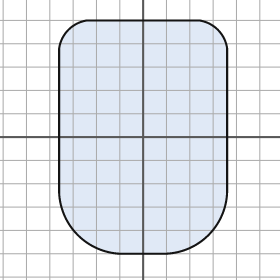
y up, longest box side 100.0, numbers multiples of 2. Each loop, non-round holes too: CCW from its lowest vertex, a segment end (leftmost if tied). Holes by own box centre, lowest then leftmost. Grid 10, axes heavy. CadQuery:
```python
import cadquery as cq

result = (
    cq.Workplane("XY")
    .moveTo(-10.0, -50.0)
    .lineTo(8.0, -50.0)
    .threePointArc((28.0, -42.0), (36.0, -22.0))
    .lineTo(36.0, 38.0)
    .threePointArc((32.0, 46.0), (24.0, 50.0))
    .lineTo(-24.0, 50.0)
    .threePointArc((-32.0, 46.0), (-36.0, 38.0))
    .lineTo(-36.0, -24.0)
    .threePointArc((-28.0, -42.0), (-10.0, -50.0))
    .close()
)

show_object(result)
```